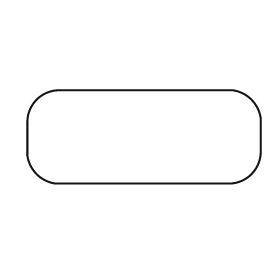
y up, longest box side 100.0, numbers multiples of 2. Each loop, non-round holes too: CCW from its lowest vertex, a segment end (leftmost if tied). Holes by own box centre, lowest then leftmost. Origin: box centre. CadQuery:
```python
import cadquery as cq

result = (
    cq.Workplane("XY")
    .moveTo(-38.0, -20.0)
    .lineTo(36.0, -20.0)
    .threePointArc((46.0, -16.0), (50.0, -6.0))
    .lineTo(50.0, 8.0)
    .threePointArc((46.0, 16.0), (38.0, 20.0))
    .lineTo(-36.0, 20.0)
    .threePointArc((-46.0, 16.0), (-50.0, 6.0))
    .lineTo(-50.0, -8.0)
    .threePointArc((-46.0, -16.0), (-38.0, -20.0))
    .close()
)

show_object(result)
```